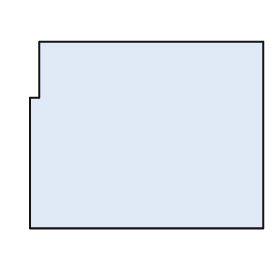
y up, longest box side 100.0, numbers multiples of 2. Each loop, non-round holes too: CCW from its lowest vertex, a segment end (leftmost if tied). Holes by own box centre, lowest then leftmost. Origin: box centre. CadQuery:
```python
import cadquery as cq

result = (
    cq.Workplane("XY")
    .moveTo(-50.0, -40.0)
    .lineTo(50.0, -40.0)
    .lineTo(50.0, 40.0)
    .lineTo(-46.0, 40.0)
    .lineTo(-46.0, 16.0)
    .lineTo(-50.0, 16.0)
    .close()
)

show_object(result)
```